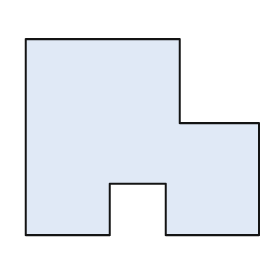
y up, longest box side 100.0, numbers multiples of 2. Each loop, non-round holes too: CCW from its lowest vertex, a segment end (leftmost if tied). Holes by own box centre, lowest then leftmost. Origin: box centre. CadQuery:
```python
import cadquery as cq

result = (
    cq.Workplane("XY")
    .moveTo(-50.0, -42.0)
    .lineTo(-14.0, -42.0)
    .lineTo(-14.0, -20.0)
    .lineTo(10.0, -20.0)
    .lineTo(10.0, -42.0)
    .lineTo(50.0, -42.0)
    .lineTo(50.0, 6.0)
    .lineTo(16.0, 6.0)
    .lineTo(16.0, 42.0)
    .lineTo(-50.0, 42.0)
    .close()
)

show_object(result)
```